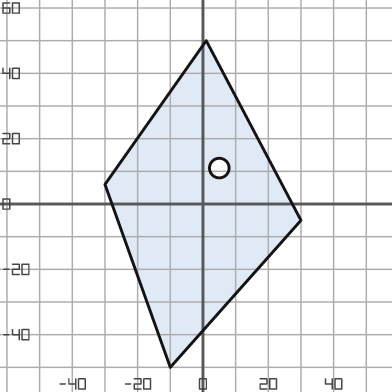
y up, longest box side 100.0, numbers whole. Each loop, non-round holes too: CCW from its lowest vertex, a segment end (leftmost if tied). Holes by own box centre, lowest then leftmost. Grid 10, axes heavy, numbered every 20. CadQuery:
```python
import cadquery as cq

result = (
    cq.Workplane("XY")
    .moveTo(-10.0, -50.0)
    .lineTo(30.0, -5.0)
    .lineTo(1.0, 50.0)
    .lineTo(-30.0, 6.0)
    .close()
    .moveTo(5.0, 11.0)
    .circle(3.0)
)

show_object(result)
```